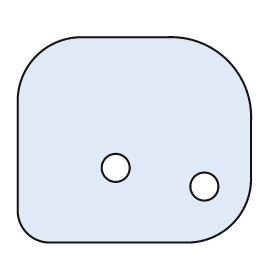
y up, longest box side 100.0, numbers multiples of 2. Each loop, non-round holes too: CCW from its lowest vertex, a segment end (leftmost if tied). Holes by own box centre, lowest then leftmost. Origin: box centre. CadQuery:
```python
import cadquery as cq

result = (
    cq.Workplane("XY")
    .moveTo(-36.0, -44.0)
    .lineTo(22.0, -44.0)
    .threePointArc((42.0, -36.0), (50.0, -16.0))
    .lineTo(50.0, 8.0)
    .threePointArc((40.0, 34.0), (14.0, 44.0))
    .lineTo(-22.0, 44.0)
    .threePointArc((-42.0, 36.0), (-50.0, 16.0))
    .lineTo(-50.0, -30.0)
    .threePointArc((-46.0, -40.0), (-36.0, -44.0))
    .close()
    .moveTo(30.0, -20.0)
    .circle(6.0)
    .moveTo(-8.0, -12.0)
    .circle(6.0)
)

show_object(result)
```